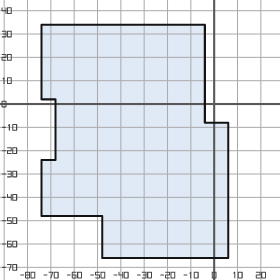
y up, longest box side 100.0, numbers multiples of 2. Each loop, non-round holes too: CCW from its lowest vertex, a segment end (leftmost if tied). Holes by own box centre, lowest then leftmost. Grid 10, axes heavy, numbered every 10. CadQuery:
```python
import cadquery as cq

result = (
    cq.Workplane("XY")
    .moveTo(-48.0, -66.0)
    .lineTo(6.0, -66.0)
    .lineTo(6.0, -8.0)
    .lineTo(-4.0, -8.0)
    .lineTo(-4.0, 34.0)
    .lineTo(-74.0, 34.0)
    .lineTo(-74.0, 2.0)
    .lineTo(-68.0, 2.0)
    .lineTo(-68.0, -24.0)
    .lineTo(-74.0, -24.0)
    .lineTo(-74.0, -48.0)
    .lineTo(-48.0, -48.0)
    .close()
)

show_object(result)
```